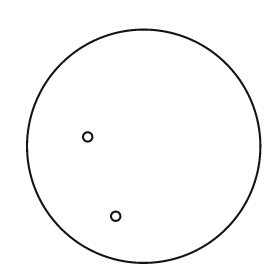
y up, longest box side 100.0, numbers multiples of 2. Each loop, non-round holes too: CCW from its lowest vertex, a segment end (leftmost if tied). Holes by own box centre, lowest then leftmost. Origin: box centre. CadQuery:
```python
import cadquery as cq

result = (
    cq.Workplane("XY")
    .moveTo(0.0, 0.0)
    .circle(50.0)
    .moveTo(-12.0, -30.0)
    .circle(2.0)
    .moveTo(-24.0, 4.0)
    .circle(2.0)
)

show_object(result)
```